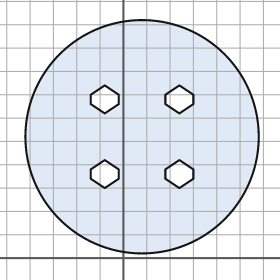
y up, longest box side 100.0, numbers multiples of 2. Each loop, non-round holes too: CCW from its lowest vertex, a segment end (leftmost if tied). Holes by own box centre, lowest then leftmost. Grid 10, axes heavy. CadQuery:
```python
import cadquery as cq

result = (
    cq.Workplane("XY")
    .moveTo(8.0, 52.0)
    .circle(50.0)
    .moveTo(-8.0, 30.0)
    .lineTo(-2.0, 34.0)
    .lineTo(-2.0, 38.0)
    .lineTo(-8.0, 42.0)
    .lineTo(-14.0, 38.0)
    .lineTo(-14.0, 34.0)
    .close()
    .moveTo(24.0, 30.0)
    .lineTo(30.0, 34.0)
    .lineTo(30.0, 38.0)
    .lineTo(24.0, 42.0)
    .lineTo(18.0, 38.0)
    .lineTo(18.0, 34.0)
    .close()
    .moveTo(-8.0, 62.0)
    .lineTo(-2.0, 66.0)
    .lineTo(-2.0, 70.0)
    .lineTo(-8.0, 74.0)
    .lineTo(-14.0, 70.0)
    .lineTo(-14.0, 66.0)
    .close()
    .moveTo(24.0, 62.0)
    .lineTo(30.0, 66.0)
    .lineTo(30.0, 70.0)
    .lineTo(24.0, 74.0)
    .lineTo(18.0, 70.0)
    .lineTo(18.0, 66.0)
    .close()
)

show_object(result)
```